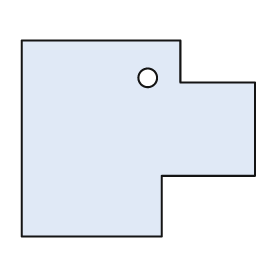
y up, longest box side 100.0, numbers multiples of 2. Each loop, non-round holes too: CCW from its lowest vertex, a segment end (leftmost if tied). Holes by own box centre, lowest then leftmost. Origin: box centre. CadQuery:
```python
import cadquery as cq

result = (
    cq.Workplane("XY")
    .moveTo(-50.0, -42.0)
    .lineTo(10.0, -42.0)
    .lineTo(10.0, -16.0)
    .lineTo(50.0, -16.0)
    .lineTo(50.0, 24.0)
    .lineTo(18.0, 24.0)
    .lineTo(18.0, 42.0)
    .lineTo(-50.0, 42.0)
    .close()
    .moveTo(4.0, 26.0)
    .circle(4.0)
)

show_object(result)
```